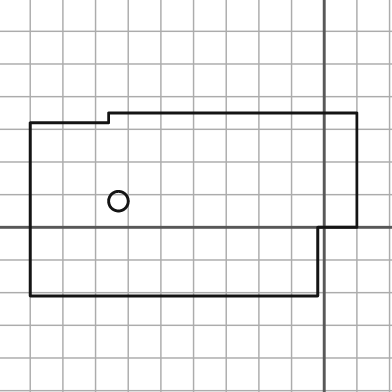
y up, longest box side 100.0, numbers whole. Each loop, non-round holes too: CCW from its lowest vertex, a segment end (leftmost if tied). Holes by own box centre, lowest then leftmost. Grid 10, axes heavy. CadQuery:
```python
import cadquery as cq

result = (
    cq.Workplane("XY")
    .moveTo(-90.0, -21.0)
    .lineTo(-2.0, -21.0)
    .lineTo(-2.0, 0.0)
    .lineTo(10.0, 0.0)
    .lineTo(10.0, 35.0)
    .lineTo(-66.0, 35.0)
    .lineTo(-66.0, 32.0)
    .lineTo(-90.0, 32.0)
    .close()
    .moveTo(-63.0, 8.0)
    .circle(3.0)
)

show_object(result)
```